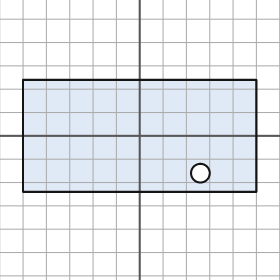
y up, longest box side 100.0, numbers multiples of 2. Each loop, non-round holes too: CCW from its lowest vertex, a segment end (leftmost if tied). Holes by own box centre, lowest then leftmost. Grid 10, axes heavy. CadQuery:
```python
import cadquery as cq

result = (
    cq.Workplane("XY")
    .moveTo(-50.0, -24.0)
    .lineTo(50.0, -24.0)
    .lineTo(50.0, 24.0)
    .lineTo(-50.0, 24.0)
    .close()
    .moveTo(26.0, -16.0)
    .circle(4.0)
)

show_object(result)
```